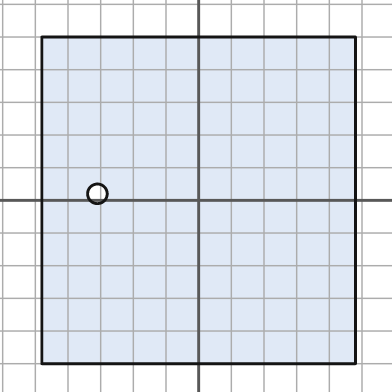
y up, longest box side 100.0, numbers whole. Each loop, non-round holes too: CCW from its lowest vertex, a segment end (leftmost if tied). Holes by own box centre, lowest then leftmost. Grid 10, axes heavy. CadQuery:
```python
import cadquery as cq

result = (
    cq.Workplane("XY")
    .moveTo(-48.0, -50.0)
    .lineTo(48.0, -50.0)
    .lineTo(48.0, 50.0)
    .lineTo(-48.0, 50.0)
    .close()
    .moveTo(-31.0, 2.0)
    .circle(3.0)
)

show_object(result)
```